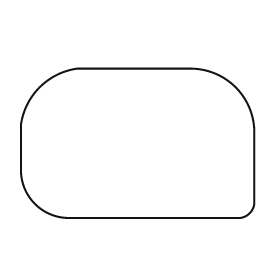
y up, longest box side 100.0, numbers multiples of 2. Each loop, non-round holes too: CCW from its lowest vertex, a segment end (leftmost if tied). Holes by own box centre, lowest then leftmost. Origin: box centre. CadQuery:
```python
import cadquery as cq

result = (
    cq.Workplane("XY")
    .moveTo(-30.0, -32.0)
    .lineTo(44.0, -32.0)
    .threePointArc((48.0, -30.0), (50.0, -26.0))
    .lineTo(50.0, 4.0)
    .threePointArc((42.0, 24.0), (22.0, 32.0))
    .lineTo(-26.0, 32.0)
    .threePointArc((-42.0, 24.0), (-50.0, 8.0))
    .lineTo(-50.0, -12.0)
    .threePointArc((-44.0, -26.0), (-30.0, -32.0))
    .close()
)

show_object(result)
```